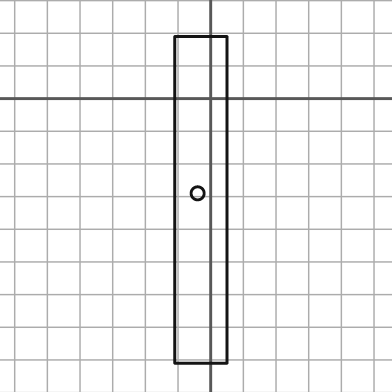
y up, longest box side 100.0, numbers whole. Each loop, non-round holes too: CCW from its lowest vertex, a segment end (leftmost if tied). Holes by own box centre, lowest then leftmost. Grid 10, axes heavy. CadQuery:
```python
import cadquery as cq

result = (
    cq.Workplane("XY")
    .moveTo(-11.0, -81.0)
    .lineTo(5.0, -81.0)
    .lineTo(5.0, 19.0)
    .lineTo(-11.0, 19.0)
    .close()
    .moveTo(-4.0, -29.0)
    .circle(2.0)
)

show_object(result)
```